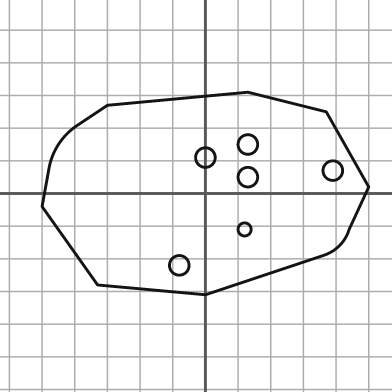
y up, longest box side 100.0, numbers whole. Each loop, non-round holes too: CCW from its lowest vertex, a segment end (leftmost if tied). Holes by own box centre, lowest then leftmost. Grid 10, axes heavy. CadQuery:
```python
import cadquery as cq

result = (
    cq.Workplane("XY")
    .moveTo(0.0, -31.0)
    .lineTo(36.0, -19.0)
    .threePointArc((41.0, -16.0), (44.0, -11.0))
    .lineTo(50.0, 2.0)
    .lineTo(37.0, 25.0)
    .lineTo(13.0, 31.0)
    .lineTo(-30.0, 27.0)
    .lineTo(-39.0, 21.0)
    .threePointArc((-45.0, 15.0), (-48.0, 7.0))
    .lineTo(-50.0, -4.0)
    .lineTo(-33.0, -28.0)
    .close()
    .moveTo(-8.0, -22.0)
    .circle(3.0)
    .moveTo(12.0, -11.0)
    .circle(2.0)
    .moveTo(13.0, 5.0)
    .circle(3.0)
    .moveTo(39.0, 7.0)
    .circle(3.0)
    .moveTo(0.0, 11.0)
    .circle(3.0)
    .moveTo(13.0, 15.0)
    .circle(3.0)
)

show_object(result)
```